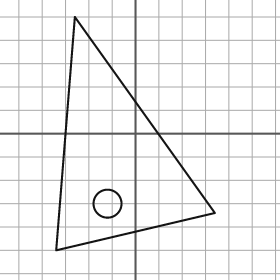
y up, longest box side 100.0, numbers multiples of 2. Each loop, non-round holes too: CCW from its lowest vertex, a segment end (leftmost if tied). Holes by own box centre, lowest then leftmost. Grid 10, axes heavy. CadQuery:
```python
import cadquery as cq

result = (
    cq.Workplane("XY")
    .moveTo(-34.0, -50.0)
    .lineTo(34.0, -34.0)
    .lineTo(-26.0, 50.0)
    .close()
    .moveTo(-12.0, -30.0)
    .circle(6.0)
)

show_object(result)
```